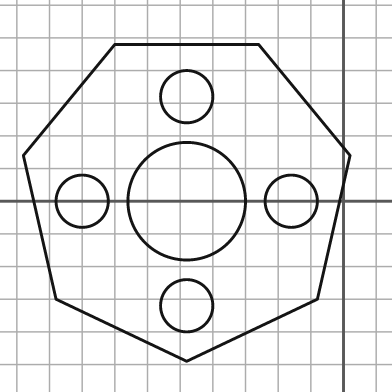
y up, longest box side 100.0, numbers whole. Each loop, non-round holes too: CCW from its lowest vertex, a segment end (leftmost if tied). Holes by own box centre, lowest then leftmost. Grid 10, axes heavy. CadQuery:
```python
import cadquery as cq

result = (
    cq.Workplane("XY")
    .moveTo(-48.0, -49.0)
    .lineTo(-8.0, -30.0)
    .lineTo(2.0, 14.0)
    .lineTo(-26.0, 48.0)
    .lineTo(-70.0, 48.0)
    .lineTo(-98.0, 14.0)
    .lineTo(-88.0, -30.0)
    .close()
    .moveTo(-48.0, -32.0)
    .circle(8.0)
    .moveTo(-80.0, 0.0)
    .circle(8.0)
    .moveTo(-48.0, 0.0)
    .circle(18.0)
    .moveTo(-16.0, 0.0)
    .circle(8.0)
    .moveTo(-48.0, 32.0)
    .circle(8.0)
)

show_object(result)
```